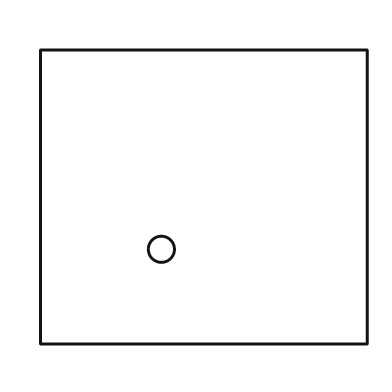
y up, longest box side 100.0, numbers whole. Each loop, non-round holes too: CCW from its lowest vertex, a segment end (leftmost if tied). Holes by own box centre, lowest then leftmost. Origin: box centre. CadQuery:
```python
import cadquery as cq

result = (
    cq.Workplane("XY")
    .moveTo(-50.0, -45.0)
    .lineTo(50.0, -45.0)
    .lineTo(50.0, 45.0)
    .lineTo(-50.0, 45.0)
    .close()
    .moveTo(-13.0, -16.0)
    .circle(4.0)
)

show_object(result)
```